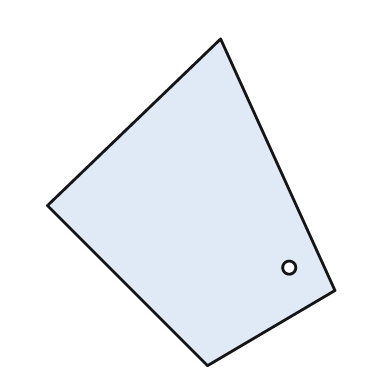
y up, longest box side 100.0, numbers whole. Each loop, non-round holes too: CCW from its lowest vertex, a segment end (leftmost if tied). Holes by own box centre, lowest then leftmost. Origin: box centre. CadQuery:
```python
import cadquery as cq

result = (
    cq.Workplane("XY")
    .moveTo(5.0, -50.0)
    .lineTo(44.0, -27.0)
    .lineTo(9.0, 50.0)
    .lineTo(-44.0, -1.0)
    .close()
    .moveTo(30.0, -20.0)
    .circle(2.0)
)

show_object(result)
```